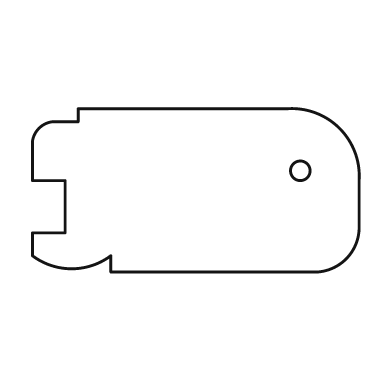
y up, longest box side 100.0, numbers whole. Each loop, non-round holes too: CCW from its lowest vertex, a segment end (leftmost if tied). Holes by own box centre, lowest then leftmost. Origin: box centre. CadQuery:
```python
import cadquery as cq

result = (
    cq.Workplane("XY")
    .moveTo(-26.0, -25.0)
    .lineTo(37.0, -25.0)
    .threePointArc((46.0, -21.0), (50.0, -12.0))
    .lineTo(50.0, 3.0)
    .threePointArc((44.0, 19.0), (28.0, 25.0))
    .lineTo(-36.0, 25.0)
    .lineTo(-36.0, 21.0)
    .lineTo(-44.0, 21.0)
    .threePointArc((-48.0, 19.0), (-50.0, 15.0))
    .lineTo(-50.0, 3.0)
    .lineTo(-40.0, 3.0)
    .lineTo(-40.0, -13.0)
    .lineTo(-50.0, -13.0)
    .lineTo(-50.0, -20.0)
    .threePointArc((-38.0, -24.0), (-26.0, -20.0))
    .close()
    .moveTo(32.0, 6.0)
    .circle(3.0)
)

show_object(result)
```